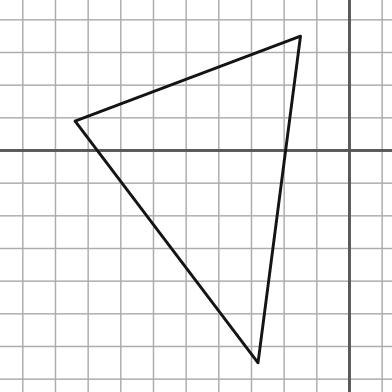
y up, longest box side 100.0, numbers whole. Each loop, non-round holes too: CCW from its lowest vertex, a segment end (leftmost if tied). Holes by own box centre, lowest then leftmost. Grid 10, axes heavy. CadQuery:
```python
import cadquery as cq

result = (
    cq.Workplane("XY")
    .moveTo(-28.0, -65.0)
    .lineTo(-15.0, 35.0)
    .lineTo(-84.0, 9.0)
    .close()
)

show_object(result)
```